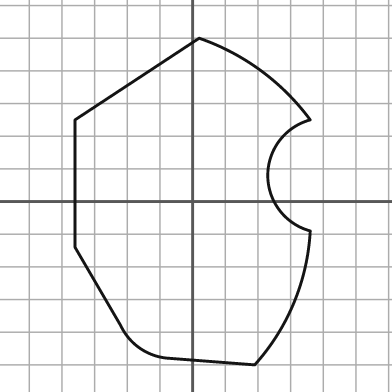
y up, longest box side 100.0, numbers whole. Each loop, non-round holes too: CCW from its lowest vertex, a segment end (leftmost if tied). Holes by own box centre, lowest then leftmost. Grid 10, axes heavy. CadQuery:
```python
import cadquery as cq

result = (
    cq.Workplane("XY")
    .moveTo(19.0, -50.0)
    .threePointArc((31.0, -31.0), (36.0, -9.0))
    .threePointArc((23.0, 8.0), (36.0, 25.0))
    .threePointArc((21.0, 40.0), (2.0, 50.0))
    .lineTo(-36.0, 25.0)
    .lineTo(-36.0, -14.0)
    .lineTo(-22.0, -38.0)
    .threePointArc((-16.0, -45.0), (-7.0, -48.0))
    .close()
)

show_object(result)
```